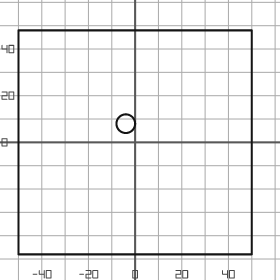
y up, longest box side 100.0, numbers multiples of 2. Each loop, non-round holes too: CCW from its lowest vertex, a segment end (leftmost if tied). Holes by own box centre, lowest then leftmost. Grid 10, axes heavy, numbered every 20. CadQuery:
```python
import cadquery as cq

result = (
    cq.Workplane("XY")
    .moveTo(-50.0, -48.0)
    .lineTo(50.0, -48.0)
    .lineTo(50.0, 48.0)
    .lineTo(-50.0, 48.0)
    .close()
    .moveTo(-4.0, 8.0)
    .circle(4.0)
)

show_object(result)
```